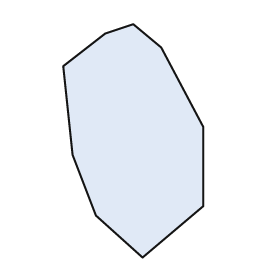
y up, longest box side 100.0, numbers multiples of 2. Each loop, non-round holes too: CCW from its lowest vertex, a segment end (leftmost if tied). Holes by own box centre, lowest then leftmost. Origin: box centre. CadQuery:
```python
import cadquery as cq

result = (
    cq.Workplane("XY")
    .moveTo(4.0, -50.0)
    .lineTo(30.0, -28.0)
    .lineTo(30.0, 6.0)
    .lineTo(12.0, 40.0)
    .lineTo(0.0, 50.0)
    .lineTo(-12.0, 46.0)
    .lineTo(-30.0, 32.0)
    .lineTo(-26.0, -6.0)
    .lineTo(-16.0, -32.0)
    .close()
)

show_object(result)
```